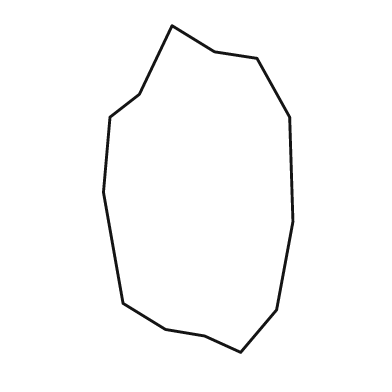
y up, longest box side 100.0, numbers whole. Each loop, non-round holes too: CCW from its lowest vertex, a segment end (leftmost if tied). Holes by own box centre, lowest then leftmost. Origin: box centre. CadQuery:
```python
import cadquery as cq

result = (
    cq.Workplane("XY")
    .moveTo(13.0, -50.0)
    .lineTo(24.0, -37.0)
    .lineTo(29.0, -10.0)
    .lineTo(28.0, 22.0)
    .lineTo(18.0, 40.0)
    .lineTo(5.0, 42.0)
    .lineTo(-8.0, 50.0)
    .lineTo(-18.0, 29.0)
    .lineTo(-27.0, 22.0)
    .lineTo(-29.0, -1.0)
    .lineTo(-23.0, -35.0)
    .lineTo(-10.0, -43.0)
    .lineTo(2.0, -45.0)
    .close()
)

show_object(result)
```